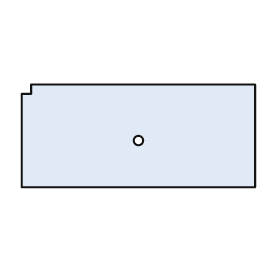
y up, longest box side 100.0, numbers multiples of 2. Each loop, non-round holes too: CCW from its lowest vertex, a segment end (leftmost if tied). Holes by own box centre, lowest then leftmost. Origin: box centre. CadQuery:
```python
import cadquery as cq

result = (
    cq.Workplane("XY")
    .moveTo(-50.0, -22.0)
    .lineTo(50.0, -22.0)
    .lineTo(50.0, 22.0)
    .lineTo(-46.0, 22.0)
    .lineTo(-46.0, 18.0)
    .lineTo(-50.0, 18.0)
    .close()
    .moveTo(0.0, -2.0)
    .circle(2.0)
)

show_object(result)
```